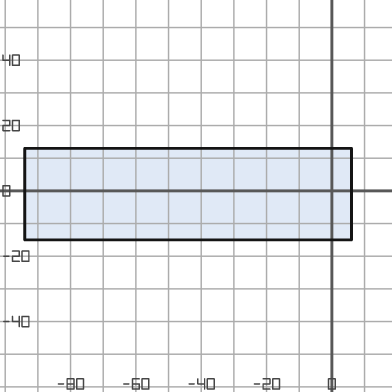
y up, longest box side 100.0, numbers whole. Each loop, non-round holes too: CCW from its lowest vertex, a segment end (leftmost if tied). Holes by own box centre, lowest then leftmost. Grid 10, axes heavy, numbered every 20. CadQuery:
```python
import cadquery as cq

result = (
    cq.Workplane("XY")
    .moveTo(-94.0, -15.0)
    .lineTo(6.0, -15.0)
    .lineTo(6.0, 13.0)
    .lineTo(-94.0, 13.0)
    .close()
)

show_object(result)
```